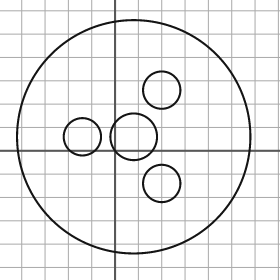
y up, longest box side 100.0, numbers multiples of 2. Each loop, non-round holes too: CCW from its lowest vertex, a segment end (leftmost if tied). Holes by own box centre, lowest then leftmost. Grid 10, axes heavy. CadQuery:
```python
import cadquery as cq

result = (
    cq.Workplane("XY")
    .moveTo(8.0, 6.0)
    .circle(50.0)
    .moveTo(20.0, -14.0)
    .circle(8.0)
    .moveTo(-14.0, 6.0)
    .circle(8.0)
    .moveTo(8.0, 6.0)
    .circle(10.0)
    .moveTo(20.0, 26.0)
    .circle(8.0)
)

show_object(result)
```